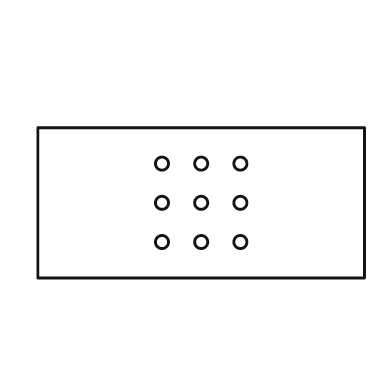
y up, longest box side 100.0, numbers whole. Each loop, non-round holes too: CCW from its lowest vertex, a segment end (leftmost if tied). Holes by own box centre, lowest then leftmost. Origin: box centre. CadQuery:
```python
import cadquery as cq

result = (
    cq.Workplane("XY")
    .moveTo(-50.0, -23.0)
    .lineTo(50.0, -23.0)
    .lineTo(50.0, 23.0)
    .lineTo(-50.0, 23.0)
    .close()
    .moveTo(-12.0, -12.0)
    .circle(2.0)
    .moveTo(0.0, -12.0)
    .circle(2.0)
    .moveTo(12.0, -12.0)
    .circle(2.0)
    .moveTo(-12.0, 0.0)
    .circle(2.0)
    .moveTo(0.0, 0.0)
    .circle(2.0)
    .moveTo(12.0, 0.0)
    .circle(2.0)
    .moveTo(-12.0, 12.0)
    .circle(2.0)
    .moveTo(0.0, 12.0)
    .circle(2.0)
    .moveTo(12.0, 12.0)
    .circle(2.0)
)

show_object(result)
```